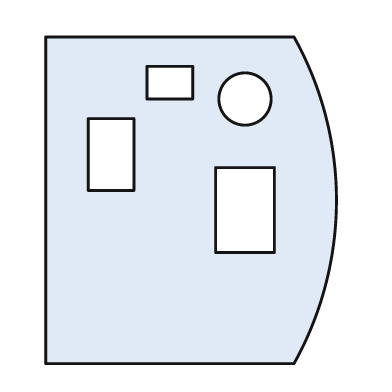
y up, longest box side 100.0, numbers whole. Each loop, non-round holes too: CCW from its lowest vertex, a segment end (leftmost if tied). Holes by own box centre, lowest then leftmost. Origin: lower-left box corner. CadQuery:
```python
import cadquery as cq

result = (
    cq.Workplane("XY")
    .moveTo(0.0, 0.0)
    .lineTo(76.0, 0.0)
    .threePointArc((89.0, 50.0), (76.0, 100.0))
    .lineTo(0.0, 100.0)
    .close()
    .moveTo(52.0, 34.0)
    .lineTo(70.0, 34.0)
    .lineTo(70.0, 60.0)
    .lineTo(52.0, 60.0)
    .close()
    .moveTo(13.0, 53.0)
    .lineTo(27.0, 53.0)
    .lineTo(27.0, 75.0)
    .lineTo(13.0, 75.0)
    .close()
    .moveTo(61.0, 81.0)
    .circle(8.0)
    .moveTo(31.0, 81.0)
    .lineTo(45.0, 81.0)
    .lineTo(45.0, 91.0)
    .lineTo(31.0, 91.0)
    .close()
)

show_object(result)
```